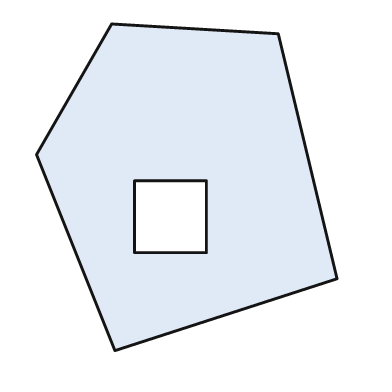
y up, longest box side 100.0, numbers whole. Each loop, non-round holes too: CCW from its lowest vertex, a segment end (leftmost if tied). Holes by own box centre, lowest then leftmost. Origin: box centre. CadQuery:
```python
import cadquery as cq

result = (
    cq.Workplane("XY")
    .moveTo(-22.0, -50.0)
    .lineTo(46.0, -28.0)
    .lineTo(28.0, 47.0)
    .lineTo(-23.0, 50.0)
    .lineTo(-46.0, 10.0)
    .close()
    .moveTo(-16.0, -20.0)
    .lineTo(6.0, -20.0)
    .lineTo(6.0, 2.0)
    .lineTo(-16.0, 2.0)
    .close()
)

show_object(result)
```